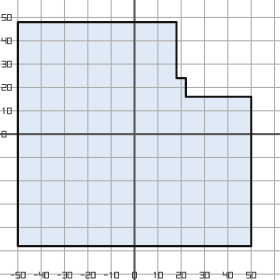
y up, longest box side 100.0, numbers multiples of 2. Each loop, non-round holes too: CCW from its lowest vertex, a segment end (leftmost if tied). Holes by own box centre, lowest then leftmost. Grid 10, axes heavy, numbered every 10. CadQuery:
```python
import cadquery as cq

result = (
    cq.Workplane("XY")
    .moveTo(-50.0, -48.0)
    .lineTo(50.0, -48.0)
    .lineTo(50.0, 16.0)
    .lineTo(22.0, 16.0)
    .lineTo(22.0, 24.0)
    .lineTo(18.0, 24.0)
    .lineTo(18.0, 48.0)
    .lineTo(-50.0, 48.0)
    .close()
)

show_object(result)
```